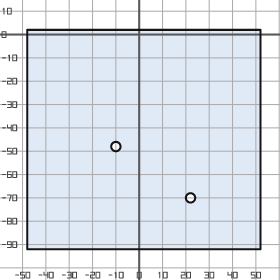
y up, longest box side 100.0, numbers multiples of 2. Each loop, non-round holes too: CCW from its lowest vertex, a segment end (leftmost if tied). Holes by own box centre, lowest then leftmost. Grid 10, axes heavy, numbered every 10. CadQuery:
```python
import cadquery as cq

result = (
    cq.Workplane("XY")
    .moveTo(-48.0, -92.0)
    .lineTo(52.0, -92.0)
    .lineTo(52.0, 2.0)
    .lineTo(-48.0, 2.0)
    .close()
    .moveTo(22.0, -70.0)
    .circle(2.0)
    .moveTo(-10.0, -48.0)
    .circle(2.0)
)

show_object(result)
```